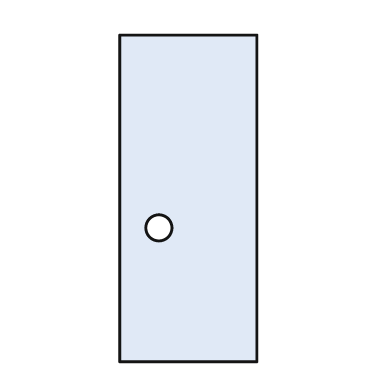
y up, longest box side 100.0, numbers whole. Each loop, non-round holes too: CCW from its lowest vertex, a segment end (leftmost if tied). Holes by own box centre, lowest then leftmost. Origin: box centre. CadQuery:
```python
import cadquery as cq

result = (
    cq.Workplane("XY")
    .moveTo(-21.0, -50.0)
    .lineTo(21.0, -50.0)
    .lineTo(21.0, 50.0)
    .lineTo(-21.0, 50.0)
    .close()
    .moveTo(-9.0, -9.0)
    .circle(4.0)
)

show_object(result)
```